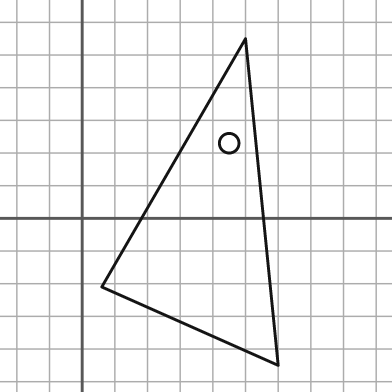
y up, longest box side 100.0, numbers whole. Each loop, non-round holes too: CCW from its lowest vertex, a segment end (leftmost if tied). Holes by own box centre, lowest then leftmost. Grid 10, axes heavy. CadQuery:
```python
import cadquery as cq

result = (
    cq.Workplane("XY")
    .moveTo(60.0, -45.0)
    .lineTo(50.0, 55.0)
    .lineTo(6.0, -21.0)
    .close()
    .moveTo(45.0, 23.0)
    .circle(3.0)
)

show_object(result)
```